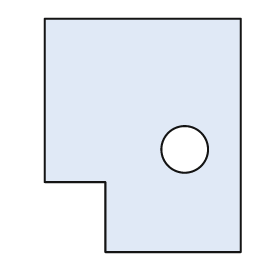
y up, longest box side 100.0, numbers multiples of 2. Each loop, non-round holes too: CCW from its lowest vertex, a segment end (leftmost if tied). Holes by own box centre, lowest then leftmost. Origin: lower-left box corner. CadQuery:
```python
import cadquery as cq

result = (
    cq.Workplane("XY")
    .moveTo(26.0, 0.0)
    .lineTo(84.0, 0.0)
    .lineTo(84.0, 100.0)
    .lineTo(0.0, 100.0)
    .lineTo(0.0, 30.0)
    .lineTo(26.0, 30.0)
    .close()
    .moveTo(60.0, 44.0)
    .circle(10.0)
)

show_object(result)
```